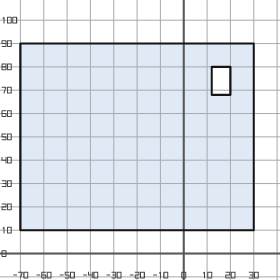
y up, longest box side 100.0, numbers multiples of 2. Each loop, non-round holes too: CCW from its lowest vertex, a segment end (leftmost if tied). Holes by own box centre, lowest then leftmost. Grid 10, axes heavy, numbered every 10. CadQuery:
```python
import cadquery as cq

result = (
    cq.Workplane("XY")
    .moveTo(-70.0, 10.0)
    .lineTo(30.0, 10.0)
    .lineTo(30.0, 90.0)
    .lineTo(-70.0, 90.0)
    .close()
    .moveTo(12.0, 68.0)
    .lineTo(20.0, 68.0)
    .lineTo(20.0, 80.0)
    .lineTo(12.0, 80.0)
    .close()
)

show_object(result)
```